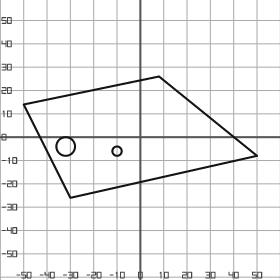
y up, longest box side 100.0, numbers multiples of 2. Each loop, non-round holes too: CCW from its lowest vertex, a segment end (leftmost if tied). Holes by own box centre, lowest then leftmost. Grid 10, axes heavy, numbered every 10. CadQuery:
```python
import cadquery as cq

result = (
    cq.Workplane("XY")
    .moveTo(-30.0, -26.0)
    .lineTo(50.0, -8.0)
    .lineTo(8.0, 26.0)
    .lineTo(-50.0, 14.0)
    .close()
    .moveTo(-10.0, -6.0)
    .circle(2.0)
    .moveTo(-32.0, -4.0)
    .circle(4.0)
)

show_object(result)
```